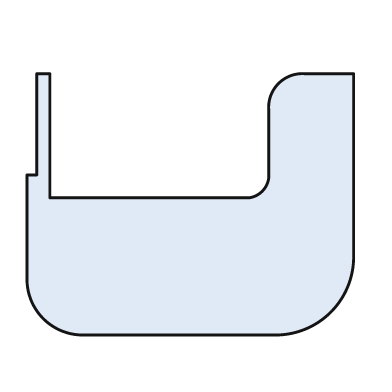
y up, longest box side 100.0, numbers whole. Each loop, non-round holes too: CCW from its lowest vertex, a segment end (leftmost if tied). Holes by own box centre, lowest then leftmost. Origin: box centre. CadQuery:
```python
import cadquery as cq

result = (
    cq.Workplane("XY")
    .moveTo(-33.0, -40.0)
    .lineTo(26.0, -40.0)
    .threePointArc((43.0, -33.0), (50.0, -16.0))
    .lineTo(50.0, 40.0)
    .lineTo(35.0, 40.0)
    .threePointArc((27.0, 37.0), (24.0, 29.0))
    .lineTo(24.0, 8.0)
    .threePointArc((22.0, 4.0), (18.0, 2.0))
    .lineTo(-43.0, 2.0)
    .lineTo(-43.0, 40.0)
    .lineTo(-47.0, 40.0)
    .lineTo(-47.0, 9.0)
    .lineTo(-50.0, 9.0)
    .lineTo(-50.0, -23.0)
    .threePointArc((-45.0, -35.0), (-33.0, -40.0))
    .close()
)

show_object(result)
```